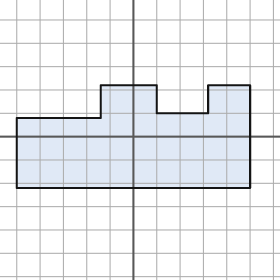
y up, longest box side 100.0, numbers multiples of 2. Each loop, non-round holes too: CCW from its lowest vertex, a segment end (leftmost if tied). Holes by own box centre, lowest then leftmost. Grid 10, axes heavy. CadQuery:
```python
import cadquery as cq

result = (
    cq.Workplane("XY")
    .moveTo(-50.0, -22.0)
    .lineTo(50.0, -22.0)
    .lineTo(50.0, 22.0)
    .lineTo(32.0, 22.0)
    .lineTo(32.0, 10.0)
    .lineTo(10.0, 10.0)
    .lineTo(10.0, 22.0)
    .lineTo(-14.0, 22.0)
    .lineTo(-14.0, 8.0)
    .lineTo(-50.0, 8.0)
    .close()
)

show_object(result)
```